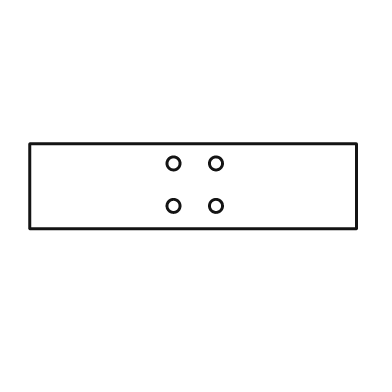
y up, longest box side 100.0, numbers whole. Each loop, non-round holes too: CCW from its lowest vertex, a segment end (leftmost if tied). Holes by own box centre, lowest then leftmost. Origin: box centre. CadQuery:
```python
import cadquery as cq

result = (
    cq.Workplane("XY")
    .moveTo(-50.0, -13.0)
    .lineTo(50.0, -13.0)
    .lineTo(50.0, 13.0)
    .lineTo(-50.0, 13.0)
    .close()
    .moveTo(-6.0, -6.0)
    .circle(2.0)
    .moveTo(7.0, -6.0)
    .circle(2.0)
    .moveTo(-6.0, 7.0)
    .circle(2.0)
    .moveTo(7.0, 7.0)
    .circle(2.0)
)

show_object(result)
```